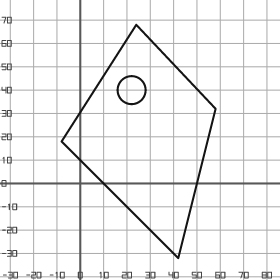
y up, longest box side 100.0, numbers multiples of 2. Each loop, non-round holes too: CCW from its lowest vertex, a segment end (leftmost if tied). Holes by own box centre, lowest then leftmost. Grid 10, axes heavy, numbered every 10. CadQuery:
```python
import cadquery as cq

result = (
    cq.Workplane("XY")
    .moveTo(42.0, -32.0)
    .lineTo(58.0, 32.0)
    .lineTo(24.0, 68.0)
    .lineTo(-8.0, 18.0)
    .close()
    .moveTo(22.0, 40.0)
    .circle(6.0)
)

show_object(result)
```